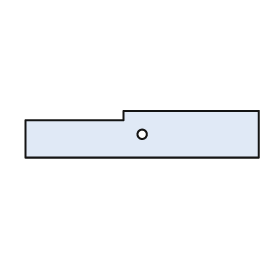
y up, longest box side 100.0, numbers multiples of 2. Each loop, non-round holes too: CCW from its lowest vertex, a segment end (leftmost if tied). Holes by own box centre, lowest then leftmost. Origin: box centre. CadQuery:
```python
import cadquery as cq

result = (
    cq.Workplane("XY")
    .moveTo(-50.0, -10.0)
    .lineTo(50.0, -10.0)
    .lineTo(50.0, 10.0)
    .lineTo(-8.0, 10.0)
    .lineTo(-8.0, 6.0)
    .lineTo(-50.0, 6.0)
    .close()
    .moveTo(0.0, 0.0)
    .circle(2.0)
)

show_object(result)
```